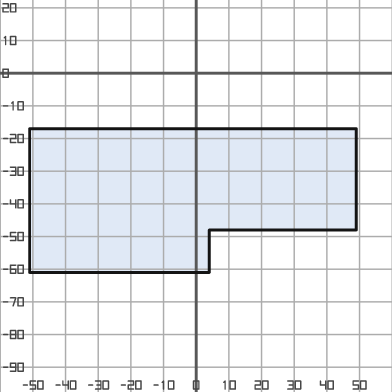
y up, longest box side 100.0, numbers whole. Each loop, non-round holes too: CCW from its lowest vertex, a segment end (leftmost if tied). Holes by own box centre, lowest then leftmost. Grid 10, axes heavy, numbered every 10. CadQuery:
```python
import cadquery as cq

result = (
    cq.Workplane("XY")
    .moveTo(-51.0, -61.0)
    .lineTo(4.0, -61.0)
    .lineTo(4.0, -48.0)
    .lineTo(49.0, -48.0)
    .lineTo(49.0, -17.0)
    .lineTo(-51.0, -17.0)
    .close()
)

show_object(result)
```